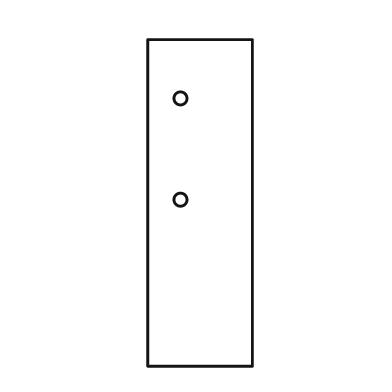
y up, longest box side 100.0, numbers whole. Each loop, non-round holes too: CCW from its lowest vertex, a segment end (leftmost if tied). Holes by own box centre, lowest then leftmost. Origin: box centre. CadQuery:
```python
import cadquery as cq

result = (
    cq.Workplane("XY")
    .moveTo(-16.0, -50.0)
    .lineTo(16.0, -50.0)
    .lineTo(16.0, 50.0)
    .lineTo(-16.0, 50.0)
    .close()
    .moveTo(-6.0, 1.0)
    .circle(2.0)
    .moveTo(-6.0, 32.0)
    .circle(2.0)
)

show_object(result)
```